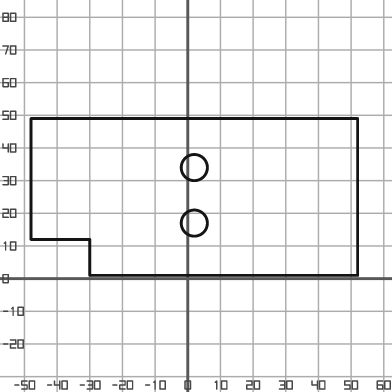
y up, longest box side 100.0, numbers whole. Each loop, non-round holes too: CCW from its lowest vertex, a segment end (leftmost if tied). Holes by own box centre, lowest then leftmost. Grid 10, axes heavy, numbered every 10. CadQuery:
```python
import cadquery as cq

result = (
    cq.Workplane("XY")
    .moveTo(-30.0, 1.0)
    .lineTo(52.0, 1.0)
    .lineTo(52.0, 49.0)
    .lineTo(-48.0, 49.0)
    .lineTo(-48.0, 12.0)
    .lineTo(-30.0, 12.0)
    .close()
    .moveTo(2.0, 17.0)
    .circle(4.0)
    .moveTo(2.0, 34.0)
    .circle(4.0)
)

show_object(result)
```